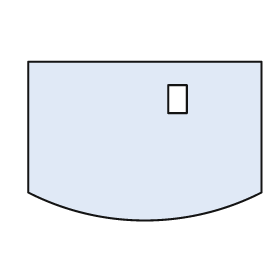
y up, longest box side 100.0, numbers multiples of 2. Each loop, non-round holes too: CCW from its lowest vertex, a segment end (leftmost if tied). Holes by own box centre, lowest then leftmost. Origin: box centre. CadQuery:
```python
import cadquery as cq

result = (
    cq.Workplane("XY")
    .moveTo(-50.0, -22.0)
    .threePointArc((0.0, -34.0), (50.0, -22.0))
    .lineTo(50.0, 34.0)
    .lineTo(-50.0, 34.0)
    .close()
    .moveTo(10.0, 12.0)
    .lineTo(18.0, 12.0)
    .lineTo(18.0, 24.0)
    .lineTo(10.0, 24.0)
    .close()
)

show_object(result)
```